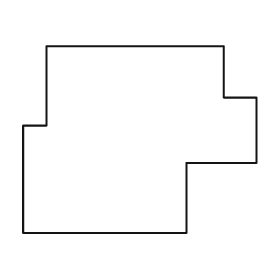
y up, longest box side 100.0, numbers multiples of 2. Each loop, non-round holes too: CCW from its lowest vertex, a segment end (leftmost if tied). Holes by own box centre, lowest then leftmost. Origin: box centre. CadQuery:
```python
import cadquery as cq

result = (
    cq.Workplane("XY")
    .moveTo(-50.0, -40.0)
    .lineTo(20.0, -40.0)
    .lineTo(20.0, -10.0)
    .lineTo(50.0, -10.0)
    .lineTo(50.0, 18.0)
    .lineTo(36.0, 18.0)
    .lineTo(36.0, 40.0)
    .lineTo(-40.0, 40.0)
    .lineTo(-40.0, 6.0)
    .lineTo(-50.0, 6.0)
    .close()
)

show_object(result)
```